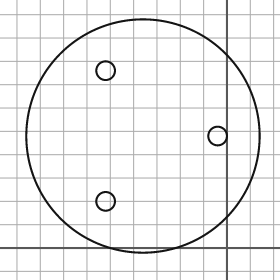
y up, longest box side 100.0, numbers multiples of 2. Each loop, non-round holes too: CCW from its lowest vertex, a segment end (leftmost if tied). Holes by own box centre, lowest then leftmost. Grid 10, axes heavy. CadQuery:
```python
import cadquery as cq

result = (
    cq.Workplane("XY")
    .moveTo(-36.0, 48.0)
    .circle(50.0)
    .moveTo(-52.0, 20.0)
    .circle(4.0)
    .moveTo(-4.0, 48.0)
    .circle(4.0)
    .moveTo(-52.0, 76.0)
    .circle(4.0)
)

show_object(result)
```